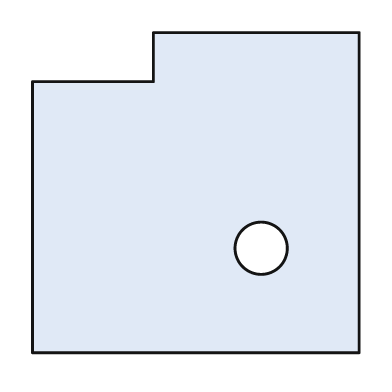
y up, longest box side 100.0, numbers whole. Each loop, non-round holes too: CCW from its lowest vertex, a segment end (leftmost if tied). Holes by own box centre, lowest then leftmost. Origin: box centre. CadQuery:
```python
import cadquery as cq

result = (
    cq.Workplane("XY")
    .moveTo(-50.0, -49.0)
    .lineTo(50.0, -49.0)
    .lineTo(50.0, 49.0)
    .lineTo(-13.0, 49.0)
    .lineTo(-13.0, 34.0)
    .lineTo(-50.0, 34.0)
    .close()
    .moveTo(20.0, -17.0)
    .circle(8.0)
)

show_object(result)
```